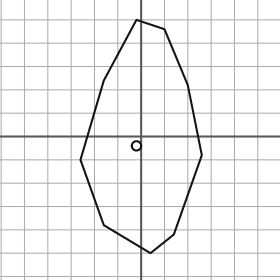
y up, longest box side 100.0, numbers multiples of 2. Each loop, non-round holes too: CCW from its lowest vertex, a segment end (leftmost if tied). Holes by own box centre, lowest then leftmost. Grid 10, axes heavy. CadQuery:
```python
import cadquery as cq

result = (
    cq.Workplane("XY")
    .moveTo(4.0, -50.0)
    .lineTo(14.0, -42.0)
    .lineTo(26.0, -8.0)
    .lineTo(20.0, 22.0)
    .lineTo(10.0, 46.0)
    .lineTo(-2.0, 50.0)
    .lineTo(-16.0, 24.0)
    .lineTo(-26.0, -10.0)
    .lineTo(-16.0, -38.0)
    .close()
    .moveTo(-2.0, -4.0)
    .circle(2.0)
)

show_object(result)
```